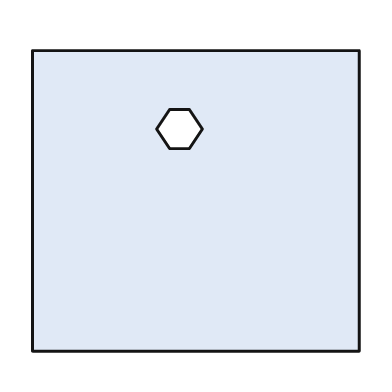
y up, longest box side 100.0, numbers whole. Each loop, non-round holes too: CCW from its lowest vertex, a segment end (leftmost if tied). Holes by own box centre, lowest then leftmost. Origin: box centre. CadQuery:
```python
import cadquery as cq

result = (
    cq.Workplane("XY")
    .moveTo(-50.0, -46.0)
    .lineTo(50.0, -46.0)
    .lineTo(50.0, 46.0)
    .lineTo(-50.0, 46.0)
    .close()
    .moveTo(-8.0, 16.0)
    .lineTo(-2.0, 16.0)
    .lineTo(2.0, 22.0)
    .lineTo(-2.0, 28.0)
    .lineTo(-8.0, 28.0)
    .lineTo(-12.0, 22.0)
    .close()
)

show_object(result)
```